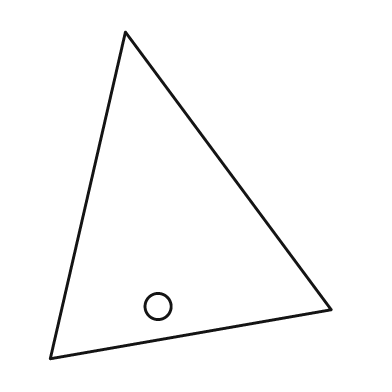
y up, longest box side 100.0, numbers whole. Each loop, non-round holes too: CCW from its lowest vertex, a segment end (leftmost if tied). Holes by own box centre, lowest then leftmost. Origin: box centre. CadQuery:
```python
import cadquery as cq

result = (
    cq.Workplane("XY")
    .moveTo(-43.0, -50.0)
    .lineTo(43.0, -35.0)
    .lineTo(-20.0, 50.0)
    .close()
    .moveTo(-10.0, -34.0)
    .circle(4.0)
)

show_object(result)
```